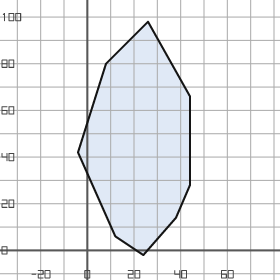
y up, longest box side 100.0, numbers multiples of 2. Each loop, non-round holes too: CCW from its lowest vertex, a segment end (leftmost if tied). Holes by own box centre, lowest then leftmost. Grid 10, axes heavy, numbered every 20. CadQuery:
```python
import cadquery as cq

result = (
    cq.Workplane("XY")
    .moveTo(24.0, -2.0)
    .lineTo(38.0, 14.0)
    .lineTo(44.0, 28.0)
    .lineTo(44.0, 66.0)
    .lineTo(26.0, 98.0)
    .lineTo(8.0, 80.0)
    .lineTo(-4.0, 42.0)
    .lineTo(12.0, 6.0)
    .close()
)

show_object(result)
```